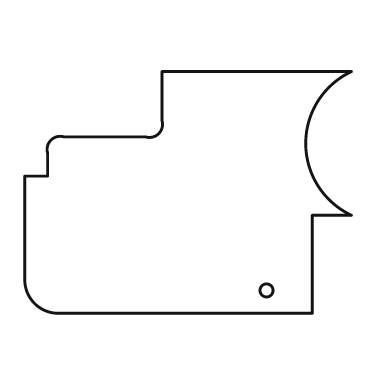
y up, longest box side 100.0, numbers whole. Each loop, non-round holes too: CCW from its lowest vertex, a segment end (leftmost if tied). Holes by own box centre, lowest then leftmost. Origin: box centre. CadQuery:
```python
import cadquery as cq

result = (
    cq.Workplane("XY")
    .moveTo(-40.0, -37.0)
    .lineTo(38.0, -37.0)
    .lineTo(38.0, -7.0)
    .lineTo(50.0, -7.0)
    .threePointArc((36.0, 15.0), (50.0, 37.0))
    .lineTo(-8.0, 37.0)
    .lineTo(-8.0, 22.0)
    .threePointArc((-9.0, 18.0), (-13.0, 17.0))
    .lineTo(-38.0, 17.0)
    .threePointArc((-42.0, 16.0), (-43.0, 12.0))
    .lineTo(-43.0, 5.0)
    .lineTo(-50.0, 5.0)
    .lineTo(-50.0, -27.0)
    .threePointArc((-47.0, -34.0), (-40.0, -37.0))
    .close()
    .moveTo(24.0, -30.0)
    .circle(2.0)
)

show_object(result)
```